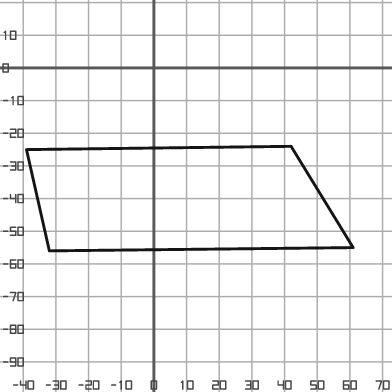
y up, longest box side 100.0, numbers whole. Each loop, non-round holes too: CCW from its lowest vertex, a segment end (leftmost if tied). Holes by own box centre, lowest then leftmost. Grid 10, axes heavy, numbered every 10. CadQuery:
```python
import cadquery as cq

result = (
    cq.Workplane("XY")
    .moveTo(-32.0, -56.0)
    .lineTo(61.0, -55.0)
    .lineTo(42.0, -24.0)
    .lineTo(-39.0, -25.0)
    .close()
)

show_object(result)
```